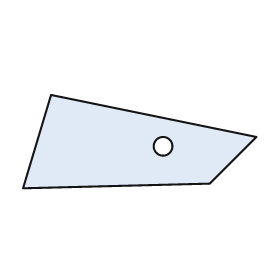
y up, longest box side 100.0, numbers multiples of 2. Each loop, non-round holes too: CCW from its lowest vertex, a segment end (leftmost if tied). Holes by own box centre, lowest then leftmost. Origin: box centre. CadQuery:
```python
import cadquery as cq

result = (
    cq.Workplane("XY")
    .moveTo(-50.0, -20.0)
    .lineTo(30.0, -18.0)
    .lineTo(50.0, 2.0)
    .lineTo(-38.0, 20.0)
    .close()
    .moveTo(10.0, -2.0)
    .circle(4.0)
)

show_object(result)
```